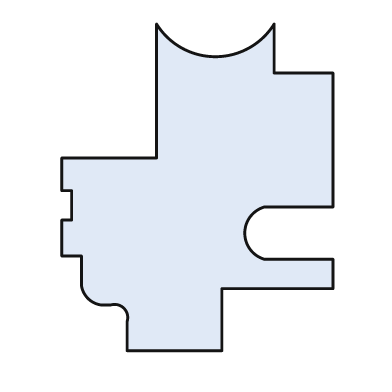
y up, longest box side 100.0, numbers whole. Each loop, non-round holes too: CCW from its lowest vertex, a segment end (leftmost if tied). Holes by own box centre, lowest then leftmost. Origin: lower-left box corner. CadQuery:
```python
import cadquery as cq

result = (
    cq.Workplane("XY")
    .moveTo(20.0, 0.0)
    .lineTo(49.0, 0.0)
    .lineTo(49.0, 19.0)
    .lineTo(83.0, 19.0)
    .lineTo(83.0, 28.0)
    .lineTo(62.0, 28.0)
    .threePointArc((56.0, 36.0), (62.0, 44.0))
    .lineTo(83.0, 44.0)
    .lineTo(83.0, 85.0)
    .lineTo(65.0, 85.0)
    .lineTo(65.0, 100.0)
    .threePointArc((47.0, 90.0), (29.0, 100.0))
    .lineTo(29.0, 59.0)
    .lineTo(0.0, 59.0)
    .lineTo(0.0, 49.0)
    .lineTo(3.0, 49.0)
    .lineTo(3.0, 40.0)
    .lineTo(0.0, 40.0)
    .lineTo(0.0, 29.0)
    .lineTo(6.0, 29.0)
    .lineTo(6.0, 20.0)
    .threePointArc((8.0, 16.0), (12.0, 14.0))
    .lineTo(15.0, 14.0)
    .threePointArc((19.0, 13.0), (20.0, 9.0))
    .close()
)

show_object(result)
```